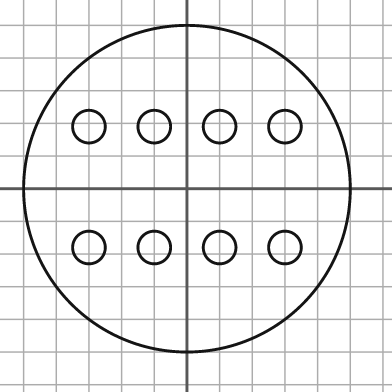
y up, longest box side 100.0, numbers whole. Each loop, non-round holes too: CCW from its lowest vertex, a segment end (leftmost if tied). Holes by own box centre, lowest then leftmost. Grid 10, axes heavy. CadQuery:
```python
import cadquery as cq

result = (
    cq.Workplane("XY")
    .moveTo(0.0, 0.0)
    .circle(50.0)
    .moveTo(-30.0, -18.0)
    .circle(5.0)
    .moveTo(-10.0, -18.0)
    .circle(5.0)
    .moveTo(10.0, -18.0)
    .circle(5.0)
    .moveTo(30.0, -18.0)
    .circle(5.0)
    .moveTo(-30.0, 19.0)
    .circle(5.0)
    .moveTo(-10.0, 19.0)
    .circle(5.0)
    .moveTo(10.0, 19.0)
    .circle(5.0)
    .moveTo(30.0, 19.0)
    .circle(5.0)
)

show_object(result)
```